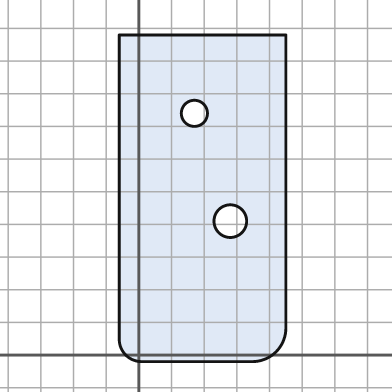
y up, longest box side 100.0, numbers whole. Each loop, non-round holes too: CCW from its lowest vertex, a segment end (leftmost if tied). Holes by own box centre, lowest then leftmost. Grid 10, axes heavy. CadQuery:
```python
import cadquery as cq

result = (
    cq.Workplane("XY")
    .moveTo(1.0, -2.0)
    .lineTo(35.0, -2.0)
    .threePointArc((42.0, 1.0), (45.0, 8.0))
    .lineTo(45.0, 98.0)
    .lineTo(-6.0, 98.0)
    .lineTo(-6.0, 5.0)
    .threePointArc((-4.0, 0.0), (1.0, -2.0))
    .close()
    .moveTo(28.0, 41.0)
    .circle(5.0)
    .moveTo(17.0, 74.0)
    .circle(4.0)
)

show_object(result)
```